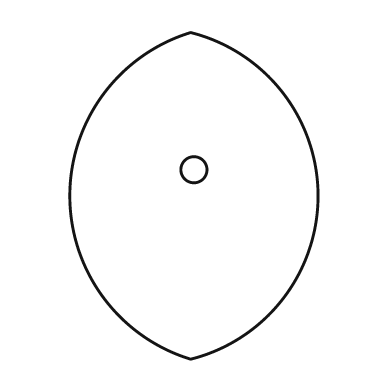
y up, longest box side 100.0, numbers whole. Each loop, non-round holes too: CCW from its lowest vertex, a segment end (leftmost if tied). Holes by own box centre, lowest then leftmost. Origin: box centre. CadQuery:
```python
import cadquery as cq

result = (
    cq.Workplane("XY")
    .moveTo(-1.0, -50.0)
    .threePointArc((38.0, 0.0), (-1.0, 50.0))
    .threePointArc((-38.0, 0.0), (-1.0, -50.0))
    .close()
    .moveTo(0.0, 8.0)
    .circle(4.0)
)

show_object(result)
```